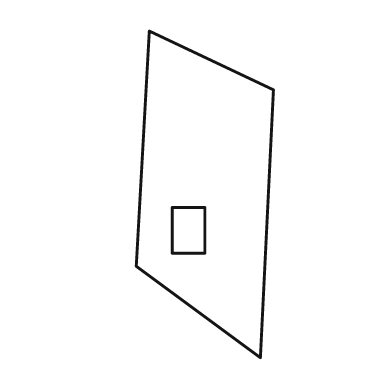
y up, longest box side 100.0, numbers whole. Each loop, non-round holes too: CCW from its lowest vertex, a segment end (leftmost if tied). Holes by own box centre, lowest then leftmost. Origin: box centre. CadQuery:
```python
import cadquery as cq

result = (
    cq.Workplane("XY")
    .moveTo(17.0, -50.0)
    .lineTo(21.0, 32.0)
    .lineTo(-17.0, 50.0)
    .lineTo(-21.0, -22.0)
    .close()
    .moveTo(-10.0, -18.0)
    .lineTo(0.0, -18.0)
    .lineTo(0.0, -4.0)
    .lineTo(-10.0, -4.0)
    .close()
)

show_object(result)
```